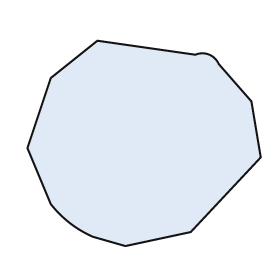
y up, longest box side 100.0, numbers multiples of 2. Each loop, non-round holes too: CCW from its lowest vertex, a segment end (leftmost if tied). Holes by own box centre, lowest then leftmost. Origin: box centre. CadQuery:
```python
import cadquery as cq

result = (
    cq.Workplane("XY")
    .moveTo(-8.0, -44.0)
    .lineTo(20.0, -38.0)
    .lineTo(50.0, -6.0)
    .lineTo(46.0, 18.0)
    .lineTo(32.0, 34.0)
    .threePointArc((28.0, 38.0), (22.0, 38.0))
    .lineTo(-20.0, 44.0)
    .lineTo(-40.0, 28.0)
    .lineTo(-50.0, -2.0)
    .lineTo(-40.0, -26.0)
    .threePointArc((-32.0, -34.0), (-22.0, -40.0))
    .close()
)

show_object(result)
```